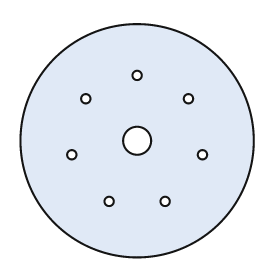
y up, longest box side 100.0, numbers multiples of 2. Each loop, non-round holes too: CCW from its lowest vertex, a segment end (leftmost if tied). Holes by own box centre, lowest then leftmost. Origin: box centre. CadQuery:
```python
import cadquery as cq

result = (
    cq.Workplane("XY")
    .moveTo(0.0, 0.0)
    .circle(50.0)
    .moveTo(-12.0, -26.0)
    .circle(2.0)
    .moveTo(12.0, -26.0)
    .circle(2.0)
    .moveTo(-28.0, -6.0)
    .circle(2.0)
    .moveTo(28.0, -6.0)
    .circle(2.0)
    .moveTo(0.0, 0.0)
    .circle(6.0)
    .moveTo(-22.0, 18.0)
    .circle(2.0)
    .moveTo(22.0, 18.0)
    .circle(2.0)
    .moveTo(0.0, 28.0)
    .circle(2.0)
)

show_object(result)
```